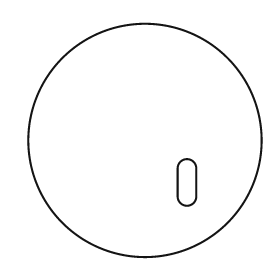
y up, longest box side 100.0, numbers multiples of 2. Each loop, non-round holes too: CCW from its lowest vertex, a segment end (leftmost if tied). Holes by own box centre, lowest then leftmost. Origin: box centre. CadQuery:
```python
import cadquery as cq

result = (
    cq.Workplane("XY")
    .moveTo(0.0, 0.0)
    .circle(50.0)
    .moveTo(14.0, -24.0)
    .threePointArc((18.0, -28.0), (22.0, -24.0))
    .lineTo(22.0, -12.0)
    .threePointArc((18.0, -8.0), (14.0, -12.0))
    .close()
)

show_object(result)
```